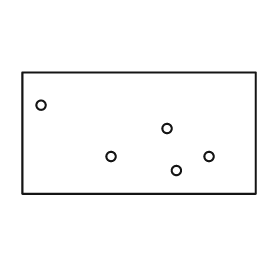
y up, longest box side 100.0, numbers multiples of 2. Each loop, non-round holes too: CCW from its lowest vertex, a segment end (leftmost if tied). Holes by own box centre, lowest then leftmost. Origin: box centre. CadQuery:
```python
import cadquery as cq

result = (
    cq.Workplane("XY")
    .moveTo(-50.0, -26.0)
    .lineTo(50.0, -26.0)
    .lineTo(50.0, 26.0)
    .lineTo(-50.0, 26.0)
    .close()
    .moveTo(16.0, -16.0)
    .circle(2.0)
    .moveTo(-12.0, -10.0)
    .circle(2.0)
    .moveTo(30.0, -10.0)
    .circle(2.0)
    .moveTo(12.0, 2.0)
    .circle(2.0)
    .moveTo(-42.0, 12.0)
    .circle(2.0)
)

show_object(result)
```